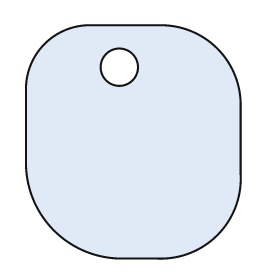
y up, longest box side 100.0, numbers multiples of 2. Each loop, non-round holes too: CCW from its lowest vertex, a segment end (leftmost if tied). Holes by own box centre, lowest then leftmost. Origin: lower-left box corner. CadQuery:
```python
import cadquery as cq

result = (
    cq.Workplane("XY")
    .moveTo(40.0, 0.0)
    .lineTo(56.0, 0.0)
    .threePointArc((82.0, 10.0), (92.0, 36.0))
    .lineTo(92.0, 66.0)
    .threePointArc((82.0, 90.0), (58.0, 100.0))
    .lineTo(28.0, 100.0)
    .threePointArc((8.0, 92.0), (0.0, 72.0))
    .lineTo(0.0, 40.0)
    .threePointArc((12.0, 12.0), (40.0, 0.0))
    .close()
    .moveTo(40.0, 82.0)
    .circle(8.0)
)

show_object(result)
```